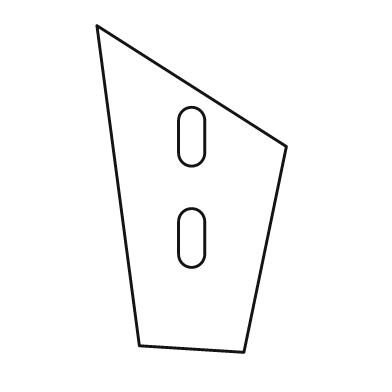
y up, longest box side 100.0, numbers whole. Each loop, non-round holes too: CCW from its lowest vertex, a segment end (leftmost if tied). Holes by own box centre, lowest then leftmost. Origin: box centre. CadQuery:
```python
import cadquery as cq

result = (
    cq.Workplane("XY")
    .moveTo(16.0, -50.0)
    .lineTo(29.0, 13.0)
    .lineTo(-29.0, 50.0)
    .lineTo(-16.0, -48.0)
    .close()
    .moveTo(-4.0, -20.0)
    .threePointArc((0.0, -24.0), (4.0, -20.0))
    .lineTo(4.0, -10.0)
    .threePointArc((0.0, -6.0), (-4.0, -10.0))
    .close()
    .moveTo(-4.0, 11.0)
    .threePointArc((0.0, 7.0), (4.0, 11.0))
    .lineTo(4.0, 21.0)
    .threePointArc((0.0, 25.0), (-4.0, 21.0))
    .close()
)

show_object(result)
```